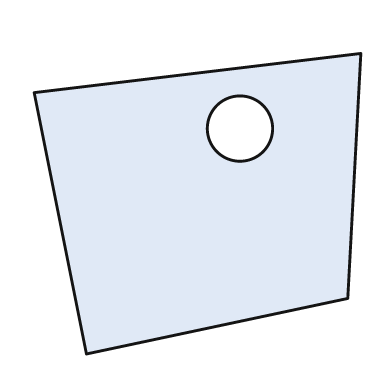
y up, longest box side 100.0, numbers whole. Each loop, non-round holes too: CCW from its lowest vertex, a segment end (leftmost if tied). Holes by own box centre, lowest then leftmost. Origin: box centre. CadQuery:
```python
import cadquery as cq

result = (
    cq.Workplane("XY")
    .moveTo(-34.0, -46.0)
    .lineTo(46.0, -29.0)
    .lineTo(50.0, 46.0)
    .lineTo(-50.0, 34.0)
    .close()
    .moveTo(13.0, 23.0)
    .circle(10.0)
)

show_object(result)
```